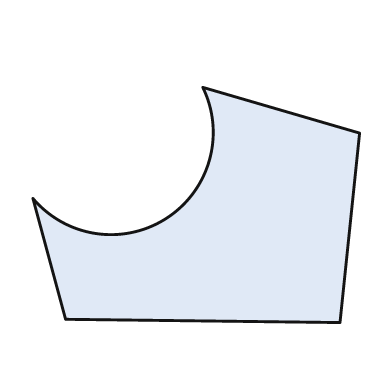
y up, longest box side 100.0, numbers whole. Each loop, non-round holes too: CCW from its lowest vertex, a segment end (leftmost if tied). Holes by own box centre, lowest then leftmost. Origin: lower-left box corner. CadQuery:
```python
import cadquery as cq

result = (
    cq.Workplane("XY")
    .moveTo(94.0, 0.0)
    .lineTo(100.0, 58.0)
    .lineTo(52.0, 72.0)
    .threePointArc((41.0, 32.0), (0.0, 38.0))
    .lineTo(10.0, 1.0)
    .close()
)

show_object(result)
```